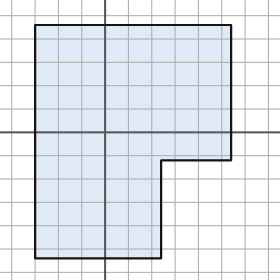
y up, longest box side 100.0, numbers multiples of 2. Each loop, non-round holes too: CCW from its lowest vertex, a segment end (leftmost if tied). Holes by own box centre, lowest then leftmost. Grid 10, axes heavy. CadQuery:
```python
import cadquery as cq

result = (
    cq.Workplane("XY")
    .moveTo(-30.0, -54.0)
    .lineTo(24.0, -54.0)
    .lineTo(24.0, -12.0)
    .lineTo(54.0, -12.0)
    .lineTo(54.0, 46.0)
    .lineTo(-30.0, 46.0)
    .close()
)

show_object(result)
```